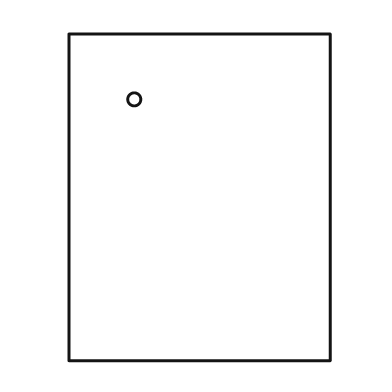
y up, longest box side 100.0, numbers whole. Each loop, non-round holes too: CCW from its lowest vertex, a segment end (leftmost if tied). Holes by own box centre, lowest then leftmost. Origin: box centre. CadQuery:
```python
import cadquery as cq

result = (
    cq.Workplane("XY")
    .moveTo(-40.0, -50.0)
    .lineTo(40.0, -50.0)
    .lineTo(40.0, 50.0)
    .lineTo(-40.0, 50.0)
    .close()
    .moveTo(-20.0, 30.0)
    .circle(2.0)
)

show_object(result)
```